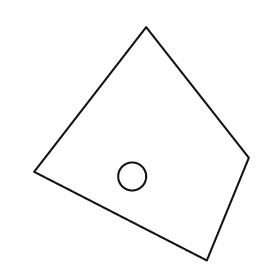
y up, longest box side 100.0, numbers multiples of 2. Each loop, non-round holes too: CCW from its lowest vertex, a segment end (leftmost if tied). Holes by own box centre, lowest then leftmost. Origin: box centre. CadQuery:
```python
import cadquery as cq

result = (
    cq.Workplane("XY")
    .moveTo(28.0, -50.0)
    .lineTo(46.0, -6.0)
    .lineTo(2.0, 50.0)
    .lineTo(-46.0, -12.0)
    .close()
    .moveTo(-4.0, -14.0)
    .circle(6.0)
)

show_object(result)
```